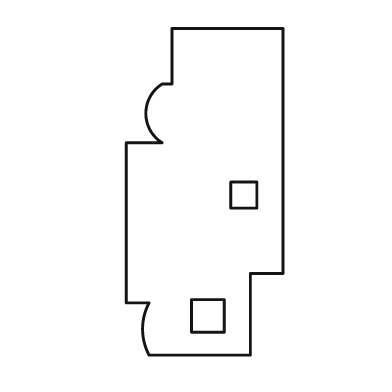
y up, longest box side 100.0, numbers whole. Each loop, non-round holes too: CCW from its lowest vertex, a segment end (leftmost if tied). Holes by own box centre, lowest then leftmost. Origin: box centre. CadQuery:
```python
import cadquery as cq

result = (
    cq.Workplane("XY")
    .moveTo(-17.0, -50.0)
    .lineTo(14.0, -50.0)
    .lineTo(14.0, -25.0)
    .lineTo(24.0, -25.0)
    .lineTo(24.0, 50.0)
    .lineTo(-10.0, 50.0)
    .lineTo(-10.0, 33.0)
    .lineTo(-13.0, 33.0)
    .threePointArc((-18.0, 24.0), (-13.0, 15.0))
    .lineTo(-24.0, 15.0)
    .lineTo(-24.0, -34.0)
    .lineTo(-17.0, -34.0)
    .threePointArc((-19.0, -42.0), (-17.0, -50.0))
    .close()
    .moveTo(-4.0, -43.0)
    .lineTo(6.0, -43.0)
    .lineTo(6.0, -33.0)
    .lineTo(-4.0, -33.0)
    .close()
    .moveTo(8.0, -5.0)
    .lineTo(16.0, -5.0)
    .lineTo(16.0, 3.0)
    .lineTo(8.0, 3.0)
    .close()
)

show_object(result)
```